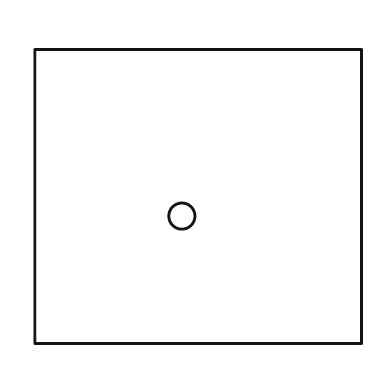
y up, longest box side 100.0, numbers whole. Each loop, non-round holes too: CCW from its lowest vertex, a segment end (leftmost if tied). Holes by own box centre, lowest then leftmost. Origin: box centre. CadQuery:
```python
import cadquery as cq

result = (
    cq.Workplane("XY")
    .moveTo(-50.0, -45.0)
    .lineTo(50.0, -45.0)
    .lineTo(50.0, 45.0)
    .lineTo(-50.0, 45.0)
    .close()
    .moveTo(-5.0, -6.0)
    .circle(4.0)
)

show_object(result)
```